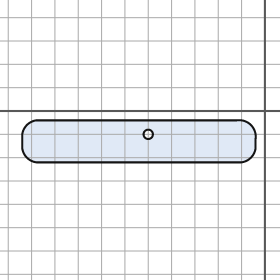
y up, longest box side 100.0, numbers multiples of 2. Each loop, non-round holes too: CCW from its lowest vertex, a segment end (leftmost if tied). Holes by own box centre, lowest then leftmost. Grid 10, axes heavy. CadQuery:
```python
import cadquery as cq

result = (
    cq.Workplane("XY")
    .moveTo(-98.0, -22.0)
    .lineTo(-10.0, -22.0)
    .threePointArc((-6.0, -20.0), (-4.0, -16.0))
    .lineTo(-4.0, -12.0)
    .threePointArc((-6.0, -6.0), (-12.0, -4.0))
    .lineTo(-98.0, -4.0)
    .threePointArc((-102.0, -6.0), (-104.0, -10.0))
    .lineTo(-104.0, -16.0)
    .threePointArc((-102.0, -20.0), (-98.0, -22.0))
    .close()
    .moveTo(-50.0, -10.0)
    .circle(2.0)
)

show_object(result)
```